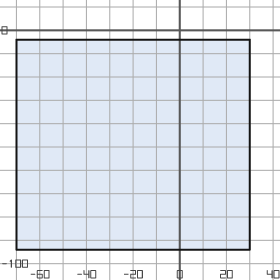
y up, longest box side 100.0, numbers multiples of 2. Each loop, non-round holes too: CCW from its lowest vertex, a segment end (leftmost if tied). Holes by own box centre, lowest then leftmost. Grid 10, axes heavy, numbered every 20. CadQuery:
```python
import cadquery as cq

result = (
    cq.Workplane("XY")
    .moveTo(-70.0, -94.0)
    .lineTo(30.0, -94.0)
    .lineTo(30.0, -4.0)
    .lineTo(-70.0, -4.0)
    .close()
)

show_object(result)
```